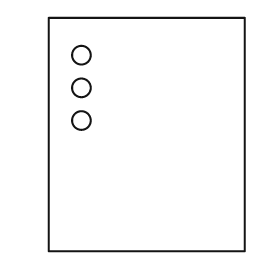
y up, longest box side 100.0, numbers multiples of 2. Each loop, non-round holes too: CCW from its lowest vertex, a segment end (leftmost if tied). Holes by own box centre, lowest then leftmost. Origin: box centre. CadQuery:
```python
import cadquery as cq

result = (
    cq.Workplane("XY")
    .moveTo(-42.0, -50.0)
    .lineTo(42.0, -50.0)
    .lineTo(42.0, 50.0)
    .lineTo(-42.0, 50.0)
    .close()
    .moveTo(-28.0, 6.0)
    .circle(4.0)
    .moveTo(-28.0, 20.0)
    .circle(4.0)
    .moveTo(-28.0, 34.0)
    .circle(4.0)
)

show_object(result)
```